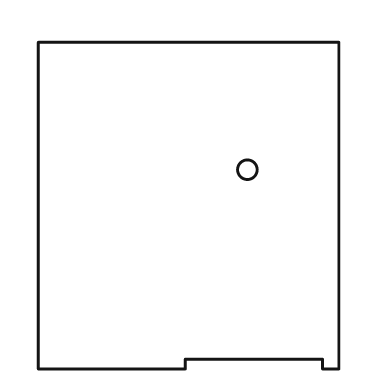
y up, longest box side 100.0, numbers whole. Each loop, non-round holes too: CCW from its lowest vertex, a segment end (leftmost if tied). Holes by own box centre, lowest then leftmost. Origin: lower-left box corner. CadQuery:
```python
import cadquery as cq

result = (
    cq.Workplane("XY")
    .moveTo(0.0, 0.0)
    .lineTo(45.0, 0.0)
    .lineTo(45.0, 3.0)
    .lineTo(87.0, 3.0)
    .lineTo(87.0, 0.0)
    .lineTo(92.0, 0.0)
    .lineTo(92.0, 100.0)
    .lineTo(0.0, 100.0)
    .close()
    .moveTo(64.0, 61.0)
    .circle(3.0)
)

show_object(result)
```